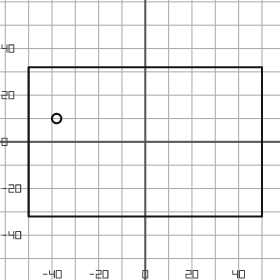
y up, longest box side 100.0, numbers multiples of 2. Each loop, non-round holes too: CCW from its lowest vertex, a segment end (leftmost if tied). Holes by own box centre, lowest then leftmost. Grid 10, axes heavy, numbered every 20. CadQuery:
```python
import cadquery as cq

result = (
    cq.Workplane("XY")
    .moveTo(-50.0, -32.0)
    .lineTo(50.0, -32.0)
    .lineTo(50.0, 32.0)
    .lineTo(-50.0, 32.0)
    .close()
    .moveTo(-38.0, 10.0)
    .circle(2.0)
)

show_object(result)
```